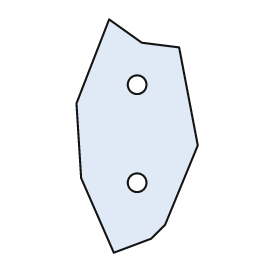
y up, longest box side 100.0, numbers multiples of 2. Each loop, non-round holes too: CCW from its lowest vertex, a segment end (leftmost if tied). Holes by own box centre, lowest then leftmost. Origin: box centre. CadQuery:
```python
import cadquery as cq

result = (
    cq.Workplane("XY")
    .moveTo(-10.0, -50.0)
    .lineTo(6.0, -44.0)
    .lineTo(12.0, -38.0)
    .lineTo(26.0, -4.0)
    .lineTo(18.0, 38.0)
    .lineTo(2.0, 40.0)
    .lineTo(-12.0, 50.0)
    .lineTo(-26.0, 14.0)
    .lineTo(-24.0, -18.0)
    .close()
    .moveTo(0.0, -20.0)
    .circle(4.0)
    .moveTo(0.0, 22.0)
    .circle(4.0)
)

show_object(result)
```